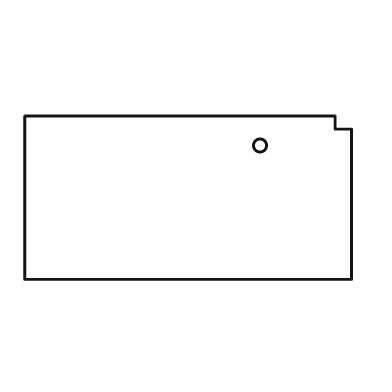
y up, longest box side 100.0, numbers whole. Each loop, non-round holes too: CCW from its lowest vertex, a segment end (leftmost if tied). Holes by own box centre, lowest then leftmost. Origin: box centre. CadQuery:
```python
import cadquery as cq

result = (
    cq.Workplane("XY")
    .moveTo(-50.0, -25.0)
    .lineTo(50.0, -25.0)
    .lineTo(50.0, 21.0)
    .lineTo(45.0, 21.0)
    .lineTo(45.0, 25.0)
    .lineTo(-50.0, 25.0)
    .close()
    .moveTo(22.0, 16.0)
    .circle(2.0)
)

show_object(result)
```